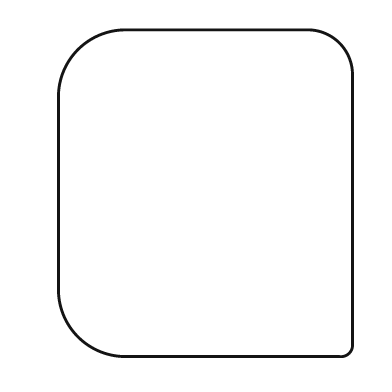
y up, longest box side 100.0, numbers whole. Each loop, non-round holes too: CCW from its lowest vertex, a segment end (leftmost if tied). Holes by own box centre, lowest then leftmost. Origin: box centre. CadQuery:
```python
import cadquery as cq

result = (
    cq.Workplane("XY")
    .moveTo(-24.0, -50.0)
    .lineTo(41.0, -50.0)
    .threePointArc((44.0, -49.0), (45.0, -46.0))
    .lineTo(45.0, 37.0)
    .threePointArc((41.0, 46.0), (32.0, 50.0))
    .lineTo(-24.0, 50.0)
    .threePointArc((-39.0, 44.0), (-45.0, 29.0))
    .lineTo(-45.0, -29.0)
    .threePointArc((-39.0, -44.0), (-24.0, -50.0))
    .close()
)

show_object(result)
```